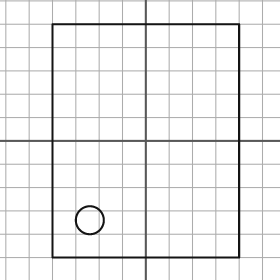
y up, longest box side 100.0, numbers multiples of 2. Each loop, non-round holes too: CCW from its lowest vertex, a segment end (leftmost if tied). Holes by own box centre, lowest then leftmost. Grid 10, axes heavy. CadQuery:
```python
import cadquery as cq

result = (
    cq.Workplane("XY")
    .moveTo(-40.0, -50.0)
    .lineTo(40.0, -50.0)
    .lineTo(40.0, 50.0)
    .lineTo(-40.0, 50.0)
    .close()
    .moveTo(-24.0, -34.0)
    .circle(6.0)
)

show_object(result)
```